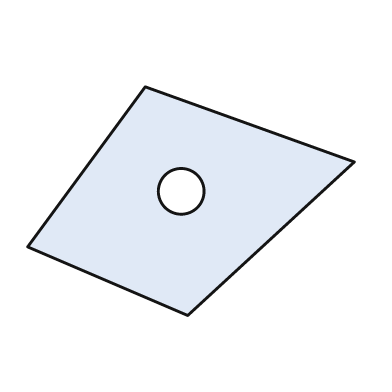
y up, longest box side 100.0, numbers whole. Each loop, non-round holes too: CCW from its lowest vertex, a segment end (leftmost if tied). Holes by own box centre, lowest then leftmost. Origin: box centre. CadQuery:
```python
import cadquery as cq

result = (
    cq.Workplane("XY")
    .moveTo(-1.0, -35.0)
    .lineTo(50.0, 12.0)
    .lineTo(-14.0, 35.0)
    .lineTo(-50.0, -14.0)
    .close()
    .moveTo(-3.0, 3.0)
    .circle(7.0)
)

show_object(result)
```